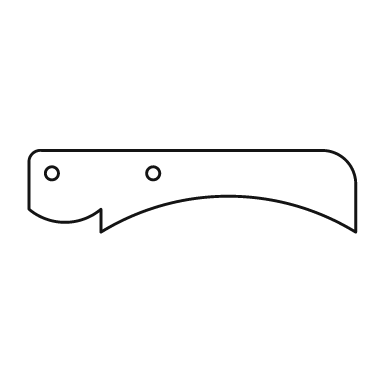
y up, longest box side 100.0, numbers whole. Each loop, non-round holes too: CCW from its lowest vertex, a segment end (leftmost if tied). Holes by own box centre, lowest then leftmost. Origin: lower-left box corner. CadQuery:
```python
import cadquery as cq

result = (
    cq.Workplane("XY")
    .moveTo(22.0, 0.0)
    .threePointArc((61.0, 11.0), (100.0, 0.0))
    .lineTo(100.0, 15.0)
    .threePointArc((97.0, 22.0), (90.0, 25.0))
    .lineTo(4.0, 25.0)
    .threePointArc((1.0, 24.0), (0.0, 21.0))
    .lineTo(0.0, 7.0)
    .threePointArc((11.0, 3.0), (22.0, 7.0))
    .close()
    .moveTo(7.0, 18.0)
    .circle(2.0)
    .moveTo(38.0, 18.0)
    .circle(2.0)
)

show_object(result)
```